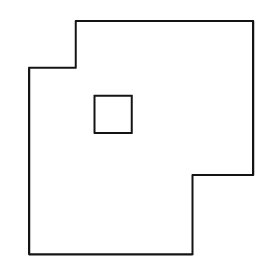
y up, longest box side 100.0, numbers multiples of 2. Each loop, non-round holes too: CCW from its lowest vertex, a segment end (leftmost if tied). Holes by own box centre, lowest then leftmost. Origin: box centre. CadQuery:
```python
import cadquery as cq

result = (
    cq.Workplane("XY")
    .moveTo(-48.0, -50.0)
    .lineTo(22.0, -50.0)
    .lineTo(22.0, -16.0)
    .lineTo(48.0, -16.0)
    .lineTo(48.0, 50.0)
    .lineTo(-28.0, 50.0)
    .lineTo(-28.0, 30.0)
    .lineTo(-48.0, 30.0)
    .close()
    .moveTo(-20.0, 2.0)
    .lineTo(-4.0, 2.0)
    .lineTo(-4.0, 18.0)
    .lineTo(-20.0, 18.0)
    .close()
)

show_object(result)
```